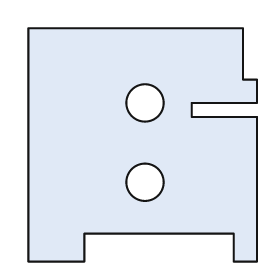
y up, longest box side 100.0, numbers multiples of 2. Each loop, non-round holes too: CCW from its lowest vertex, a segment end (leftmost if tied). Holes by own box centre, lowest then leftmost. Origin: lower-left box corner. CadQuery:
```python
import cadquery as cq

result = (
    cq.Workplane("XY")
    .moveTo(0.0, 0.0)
    .lineTo(24.0, 0.0)
    .lineTo(24.0, 12.0)
    .lineTo(88.0, 12.0)
    .lineTo(88.0, 0.0)
    .lineTo(98.0, 0.0)
    .lineTo(98.0, 62.0)
    .lineTo(70.0, 62.0)
    .lineTo(70.0, 68.0)
    .lineTo(98.0, 68.0)
    .lineTo(98.0, 78.0)
    .lineTo(92.0, 78.0)
    .lineTo(92.0, 100.0)
    .lineTo(0.0, 100.0)
    .close()
    .moveTo(50.0, 34.0)
    .circle(8.0)
    .moveTo(50.0, 68.0)
    .circle(8.0)
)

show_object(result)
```